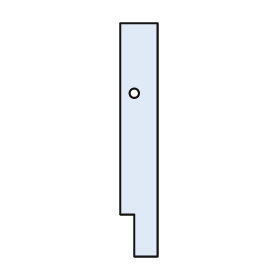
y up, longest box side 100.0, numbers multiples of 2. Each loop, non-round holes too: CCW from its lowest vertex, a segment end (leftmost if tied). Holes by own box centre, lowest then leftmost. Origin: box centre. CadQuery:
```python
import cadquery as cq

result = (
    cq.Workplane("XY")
    .moveTo(-2.0, -50.0)
    .lineTo(8.0, -50.0)
    .lineTo(8.0, 50.0)
    .lineTo(-8.0, 50.0)
    .lineTo(-8.0, -32.0)
    .lineTo(-2.0, -32.0)
    .close()
    .moveTo(-2.0, 20.0)
    .circle(2.0)
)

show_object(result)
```